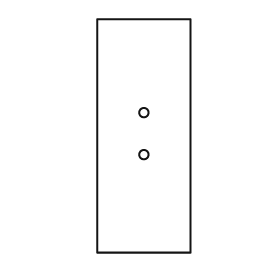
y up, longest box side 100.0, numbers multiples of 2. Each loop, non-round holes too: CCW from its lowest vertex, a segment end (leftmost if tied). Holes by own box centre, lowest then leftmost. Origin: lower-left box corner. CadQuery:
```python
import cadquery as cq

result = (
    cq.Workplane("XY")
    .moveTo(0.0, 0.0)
    .lineTo(40.0, 0.0)
    .lineTo(40.0, 100.0)
    .lineTo(0.0, 100.0)
    .close()
    .moveTo(20.0, 42.0)
    .circle(2.0)
    .moveTo(20.0, 60.0)
    .circle(2.0)
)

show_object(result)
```